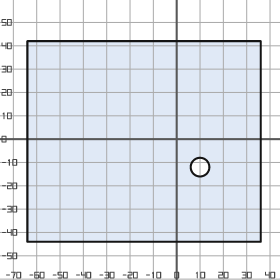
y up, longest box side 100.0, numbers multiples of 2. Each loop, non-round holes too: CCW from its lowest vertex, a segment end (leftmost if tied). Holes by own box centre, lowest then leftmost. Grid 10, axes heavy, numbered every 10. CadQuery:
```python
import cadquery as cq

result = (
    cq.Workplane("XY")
    .moveTo(-64.0, -44.0)
    .lineTo(36.0, -44.0)
    .lineTo(36.0, 42.0)
    .lineTo(-64.0, 42.0)
    .close()
    .moveTo(10.0, -12.0)
    .circle(4.0)
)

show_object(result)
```